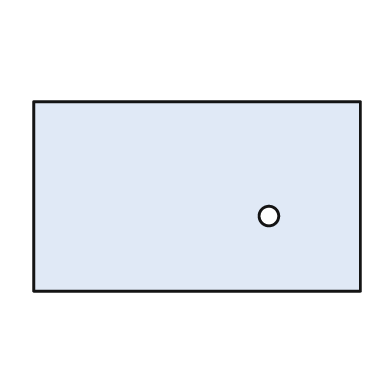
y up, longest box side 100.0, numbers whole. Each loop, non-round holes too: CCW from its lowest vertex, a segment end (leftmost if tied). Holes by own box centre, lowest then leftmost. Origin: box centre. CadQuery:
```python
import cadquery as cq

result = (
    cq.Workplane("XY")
    .moveTo(-50.0, -29.0)
    .lineTo(50.0, -29.0)
    .lineTo(50.0, 29.0)
    .lineTo(-50.0, 29.0)
    .close()
    .moveTo(22.0, -6.0)
    .circle(3.0)
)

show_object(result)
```